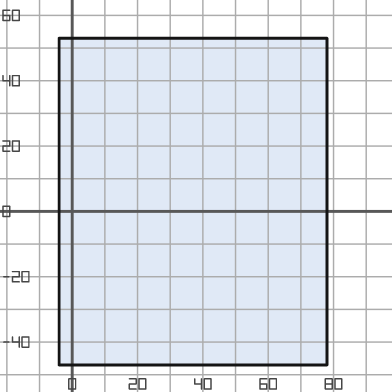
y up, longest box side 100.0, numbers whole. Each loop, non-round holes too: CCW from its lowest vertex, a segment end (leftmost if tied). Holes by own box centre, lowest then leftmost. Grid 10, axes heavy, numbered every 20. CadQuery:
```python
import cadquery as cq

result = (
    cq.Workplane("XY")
    .moveTo(-4.0, -47.0)
    .lineTo(78.0, -47.0)
    .lineTo(78.0, 53.0)
    .lineTo(-4.0, 53.0)
    .close()
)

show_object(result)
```